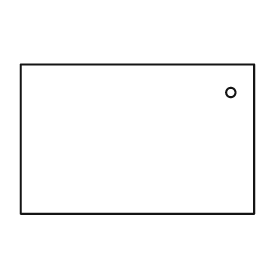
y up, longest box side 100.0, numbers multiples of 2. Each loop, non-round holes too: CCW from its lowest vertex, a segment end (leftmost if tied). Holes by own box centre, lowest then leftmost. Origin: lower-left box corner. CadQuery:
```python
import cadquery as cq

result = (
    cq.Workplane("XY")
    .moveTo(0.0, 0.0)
    .lineTo(100.0, 0.0)
    .lineTo(100.0, 64.0)
    .lineTo(0.0, 64.0)
    .close()
    .moveTo(90.0, 52.0)
    .circle(2.0)
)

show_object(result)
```